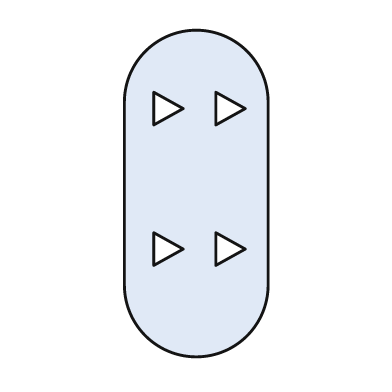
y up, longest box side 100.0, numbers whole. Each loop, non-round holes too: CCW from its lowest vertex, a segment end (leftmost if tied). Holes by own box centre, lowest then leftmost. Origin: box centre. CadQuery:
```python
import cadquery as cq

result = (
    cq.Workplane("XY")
    .moveTo(-22.0, -28.0)
    .threePointArc((0.0, -50.0), (22.0, -28.0))
    .lineTo(22.0, 28.0)
    .threePointArc((0.0, 50.0), (-22.0, 28.0))
    .close()
    .moveTo(-13.0, -22.0)
    .lineTo(-4.0, -17.0)
    .lineTo(-13.0, -12.0)
    .close()
    .moveTo(6.0, -22.0)
    .lineTo(15.0, -17.0)
    .lineTo(6.0, -12.0)
    .close()
    .moveTo(-13.0, 21.0)
    .lineTo(-4.0, 26.0)
    .lineTo(-13.0, 31.0)
    .close()
    .moveTo(6.0, 21.0)
    .lineTo(15.0, 26.0)
    .lineTo(6.0, 31.0)
    .close()
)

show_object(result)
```